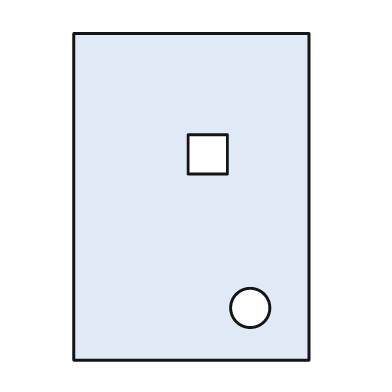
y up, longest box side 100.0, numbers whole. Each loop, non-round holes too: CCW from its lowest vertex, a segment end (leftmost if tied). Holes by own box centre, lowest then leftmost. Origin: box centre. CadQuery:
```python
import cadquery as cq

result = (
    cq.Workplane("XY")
    .moveTo(-36.0, -50.0)
    .lineTo(36.0, -50.0)
    .lineTo(36.0, 50.0)
    .lineTo(-36.0, 50.0)
    .close()
    .moveTo(18.0, -34.0)
    .circle(6.0)
    .moveTo(-1.0, 7.0)
    .lineTo(11.0, 7.0)
    .lineTo(11.0, 19.0)
    .lineTo(-1.0, 19.0)
    .close()
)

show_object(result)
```